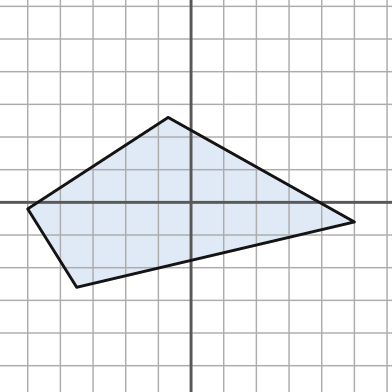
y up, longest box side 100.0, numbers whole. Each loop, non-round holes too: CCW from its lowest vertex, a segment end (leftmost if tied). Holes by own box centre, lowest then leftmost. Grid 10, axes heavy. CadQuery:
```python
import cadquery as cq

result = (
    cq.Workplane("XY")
    .moveTo(-35.0, -26.0)
    .lineTo(50.0, -6.0)
    .lineTo(-7.0, 26.0)
    .lineTo(-50.0, -2.0)
    .close()
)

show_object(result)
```